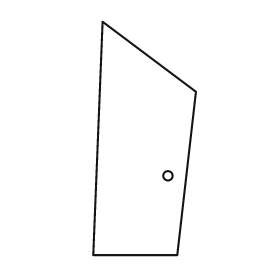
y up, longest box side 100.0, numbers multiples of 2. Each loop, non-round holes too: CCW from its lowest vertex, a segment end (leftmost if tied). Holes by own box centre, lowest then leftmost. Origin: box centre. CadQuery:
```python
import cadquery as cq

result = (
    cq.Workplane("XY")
    .moveTo(-22.0, -50.0)
    .lineTo(14.0, -50.0)
    .lineTo(22.0, 20.0)
    .lineTo(-18.0, 50.0)
    .close()
    .moveTo(10.0, -16.0)
    .circle(2.0)
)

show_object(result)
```